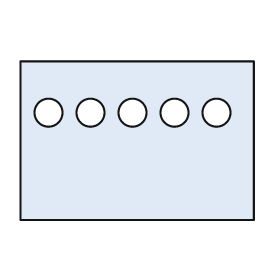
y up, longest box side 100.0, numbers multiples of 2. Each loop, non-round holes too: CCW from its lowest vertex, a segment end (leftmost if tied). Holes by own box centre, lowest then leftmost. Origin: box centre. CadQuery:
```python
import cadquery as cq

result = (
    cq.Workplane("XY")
    .moveTo(-50.0, -34.0)
    .lineTo(50.0, -34.0)
    .lineTo(50.0, 34.0)
    .lineTo(-50.0, 34.0)
    .close()
    .moveTo(-38.0, 12.0)
    .circle(6.0)
    .moveTo(-20.0, 12.0)
    .circle(6.0)
    .moveTo(-2.0, 12.0)
    .circle(6.0)
    .moveTo(16.0, 12.0)
    .circle(6.0)
    .moveTo(34.0, 12.0)
    .circle(6.0)
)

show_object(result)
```